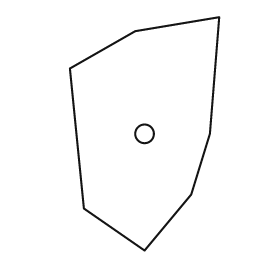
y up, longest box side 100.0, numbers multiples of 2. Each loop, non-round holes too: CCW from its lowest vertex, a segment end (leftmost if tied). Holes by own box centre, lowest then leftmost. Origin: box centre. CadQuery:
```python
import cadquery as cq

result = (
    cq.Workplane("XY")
    .moveTo(0.0, -50.0)
    .lineTo(20.0, -26.0)
    .lineTo(28.0, 0.0)
    .lineTo(32.0, 50.0)
    .lineTo(-4.0, 44.0)
    .lineTo(-32.0, 28.0)
    .lineTo(-26.0, -32.0)
    .close()
    .moveTo(0.0, 0.0)
    .circle(4.0)
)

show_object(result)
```